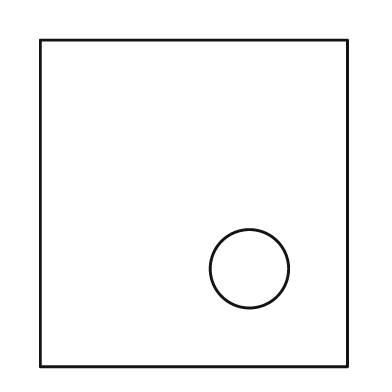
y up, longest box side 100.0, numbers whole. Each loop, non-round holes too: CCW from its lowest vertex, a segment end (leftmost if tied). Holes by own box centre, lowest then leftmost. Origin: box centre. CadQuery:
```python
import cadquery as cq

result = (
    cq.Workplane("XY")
    .moveTo(-47.0, -50.0)
    .lineTo(47.0, -50.0)
    .lineTo(47.0, 50.0)
    .lineTo(-47.0, 50.0)
    .close()
    .moveTo(17.0, -20.0)
    .circle(12.0)
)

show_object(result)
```